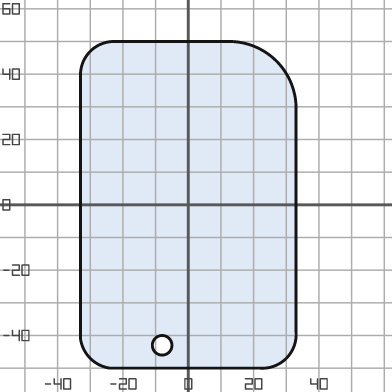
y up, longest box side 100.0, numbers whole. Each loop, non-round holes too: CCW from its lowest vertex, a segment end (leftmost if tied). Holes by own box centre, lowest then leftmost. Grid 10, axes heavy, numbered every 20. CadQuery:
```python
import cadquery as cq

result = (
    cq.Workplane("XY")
    .moveTo(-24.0, -50.0)
    .lineTo(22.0, -50.0)
    .threePointArc((30.0, -47.0), (33.0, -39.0))
    .lineTo(33.0, 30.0)
    .threePointArc((27.0, 44.0), (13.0, 50.0))
    .lineTo(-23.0, 50.0)
    .threePointArc((-30.0, 47.0), (-33.0, 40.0))
    .lineTo(-33.0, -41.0)
    .threePointArc((-30.0, -47.0), (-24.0, -50.0))
    .close()
    .moveTo(-8.0, -43.0)
    .circle(3.0)
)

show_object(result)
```